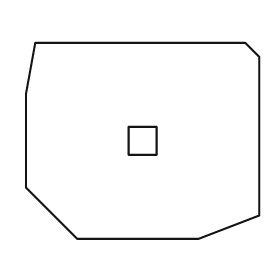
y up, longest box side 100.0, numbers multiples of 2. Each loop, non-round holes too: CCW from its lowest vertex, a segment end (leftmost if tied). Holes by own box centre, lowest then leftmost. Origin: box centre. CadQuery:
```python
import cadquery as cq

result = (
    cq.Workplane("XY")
    .moveTo(-28.0, -42.0)
    .lineTo(24.0, -42.0)
    .lineTo(50.0, -32.0)
    .lineTo(50.0, 36.0)
    .lineTo(44.0, 42.0)
    .lineTo(-46.0, 42.0)
    .lineTo(-50.0, 20.0)
    .lineTo(-50.0, -20.0)
    .close()
    .moveTo(-6.0, -6.0)
    .lineTo(6.0, -6.0)
    .lineTo(6.0, 6.0)
    .lineTo(-6.0, 6.0)
    .close()
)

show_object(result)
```